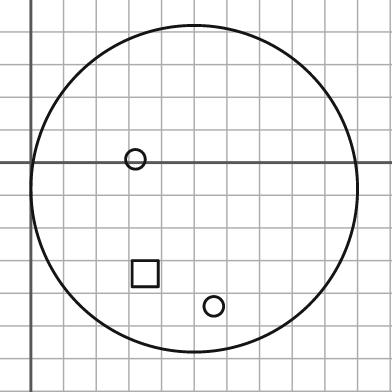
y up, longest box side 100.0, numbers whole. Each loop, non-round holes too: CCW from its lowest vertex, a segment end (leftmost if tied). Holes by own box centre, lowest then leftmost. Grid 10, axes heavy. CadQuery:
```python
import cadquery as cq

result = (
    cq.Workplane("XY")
    .moveTo(50.0, -8.0)
    .circle(50.0)
    .moveTo(56.0, -44.0)
    .circle(3.0)
    .moveTo(31.0, -38.0)
    .lineTo(39.0, -38.0)
    .lineTo(39.0, -30.0)
    .lineTo(31.0, -30.0)
    .close()
    .moveTo(32.0, 1.0)
    .circle(3.0)
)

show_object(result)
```